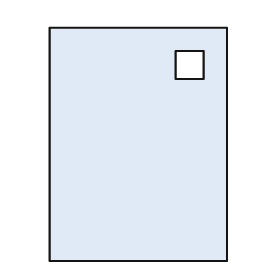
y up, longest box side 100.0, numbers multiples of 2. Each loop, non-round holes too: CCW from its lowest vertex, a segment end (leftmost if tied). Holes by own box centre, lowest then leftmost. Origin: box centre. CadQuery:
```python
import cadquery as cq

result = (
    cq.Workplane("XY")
    .moveTo(-38.0, -50.0)
    .lineTo(38.0, -50.0)
    .lineTo(38.0, 50.0)
    .lineTo(-38.0, 50.0)
    .close()
    .moveTo(16.0, 28.0)
    .lineTo(28.0, 28.0)
    .lineTo(28.0, 40.0)
    .lineTo(16.0, 40.0)
    .close()
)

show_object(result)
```